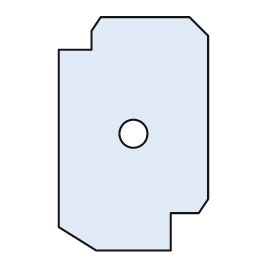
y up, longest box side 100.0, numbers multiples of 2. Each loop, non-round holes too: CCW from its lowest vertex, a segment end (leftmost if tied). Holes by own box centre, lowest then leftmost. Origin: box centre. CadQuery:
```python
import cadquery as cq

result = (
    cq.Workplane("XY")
    .moveTo(-16.0, -50.0)
    .lineTo(16.0, -50.0)
    .lineTo(16.0, -34.0)
    .lineTo(28.0, -34.0)
    .lineTo(32.0, -28.0)
    .lineTo(32.0, 42.0)
    .lineTo(24.0, 50.0)
    .lineTo(-14.0, 50.0)
    .lineTo(-18.0, 44.0)
    .lineTo(-18.0, 36.0)
    .lineTo(-32.0, 36.0)
    .lineTo(-32.0, -40.0)
    .close()
    .moveTo(0.0, 0.0)
    .circle(6.0)
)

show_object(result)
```